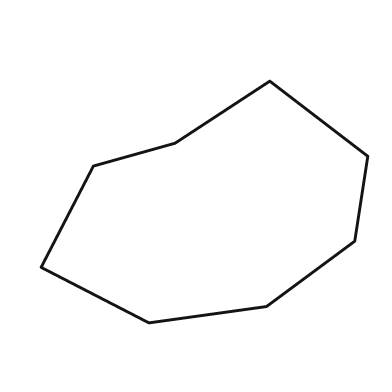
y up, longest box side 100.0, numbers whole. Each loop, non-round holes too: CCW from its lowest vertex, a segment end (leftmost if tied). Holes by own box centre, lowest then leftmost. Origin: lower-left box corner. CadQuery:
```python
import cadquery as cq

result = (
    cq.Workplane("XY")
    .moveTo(33.0, 0.0)
    .lineTo(69.0, 5.0)
    .lineTo(96.0, 25.0)
    .lineTo(100.0, 51.0)
    .lineTo(70.0, 74.0)
    .lineTo(41.0, 55.0)
    .lineTo(16.0, 48.0)
    .lineTo(0.0, 17.0)
    .close()
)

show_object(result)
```